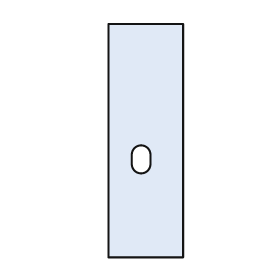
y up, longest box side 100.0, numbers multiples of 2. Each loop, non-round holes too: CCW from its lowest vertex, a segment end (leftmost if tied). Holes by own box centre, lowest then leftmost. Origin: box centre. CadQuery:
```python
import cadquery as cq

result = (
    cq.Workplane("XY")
    .moveTo(-16.0, -50.0)
    .lineTo(16.0, -50.0)
    .lineTo(16.0, 50.0)
    .lineTo(-16.0, 50.0)
    .close()
    .moveTo(-6.0, -10.0)
    .threePointArc((-2.0, -14.0), (2.0, -10.0))
    .lineTo(2.0, -6.0)
    .threePointArc((-2.0, -2.0), (-6.0, -6.0))
    .close()
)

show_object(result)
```